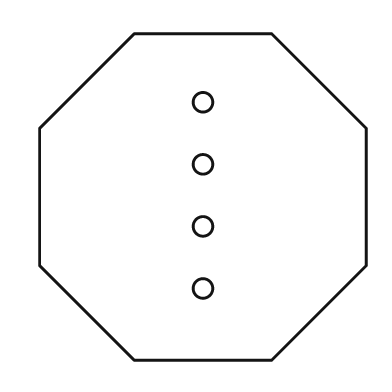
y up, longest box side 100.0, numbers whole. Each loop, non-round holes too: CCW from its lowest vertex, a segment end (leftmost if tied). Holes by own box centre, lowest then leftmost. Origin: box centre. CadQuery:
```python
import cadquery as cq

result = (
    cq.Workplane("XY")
    .moveTo(-21.0, -50.0)
    .lineTo(21.0, -50.0)
    .lineTo(50.0, -21.0)
    .lineTo(50.0, 21.0)
    .lineTo(21.0, 50.0)
    .lineTo(-21.0, 50.0)
    .lineTo(-50.0, 21.0)
    .lineTo(-50.0, -21.0)
    .close()
    .moveTo(0.0, -28.0)
    .circle(3.0)
    .moveTo(0.0, -9.0)
    .circle(3.0)
    .moveTo(0.0, 10.0)
    .circle(3.0)
    .moveTo(0.0, 29.0)
    .circle(3.0)
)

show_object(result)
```